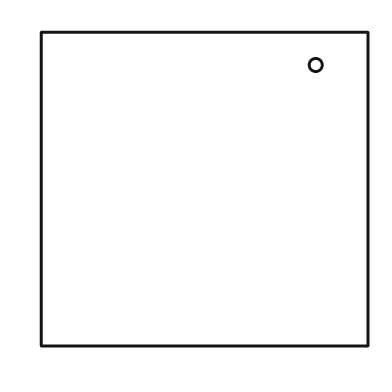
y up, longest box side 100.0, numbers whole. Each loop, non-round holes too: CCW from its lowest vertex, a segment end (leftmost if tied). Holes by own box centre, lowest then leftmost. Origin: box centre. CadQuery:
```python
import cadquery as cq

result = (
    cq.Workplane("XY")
    .moveTo(-50.0, -48.0)
    .lineTo(50.0, -48.0)
    .lineTo(50.0, 48.0)
    .lineTo(-50.0, 48.0)
    .close()
    .moveTo(34.0, 38.0)
    .circle(2.0)
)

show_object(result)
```